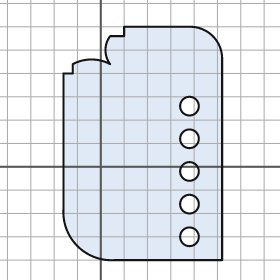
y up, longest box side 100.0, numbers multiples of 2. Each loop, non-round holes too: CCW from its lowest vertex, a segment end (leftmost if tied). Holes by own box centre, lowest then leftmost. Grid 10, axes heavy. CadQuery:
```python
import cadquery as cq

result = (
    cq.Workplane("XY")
    .moveTo(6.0, -40.0)
    .lineTo(52.0, -40.0)
    .lineTo(52.0, 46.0)
    .threePointArc((48.0, 56.0), (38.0, 60.0))
    .lineTo(10.0, 60.0)
    .lineTo(10.0, 56.0)
    .lineTo(4.0, 56.0)
    .threePointArc((2.0, 50.0), (4.0, 44.0))
    .threePointArc((-4.0, 46.0), (-12.0, 44.0))
    .lineTo(-12.0, 40.0)
    .lineTo(-16.0, 40.0)
    .lineTo(-16.0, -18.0)
    .threePointArc((-10.0, -34.0), (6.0, -40.0))
    .close()
    .moveTo(38.0, -30.0)
    .circle(4.0)
    .moveTo(38.0, -16.0)
    .circle(4.0)
    .moveTo(38.0, -2.0)
    .circle(4.0)
    .moveTo(38.0, 12.0)
    .circle(4.0)
    .moveTo(38.0, 26.0)
    .circle(4.0)
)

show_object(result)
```